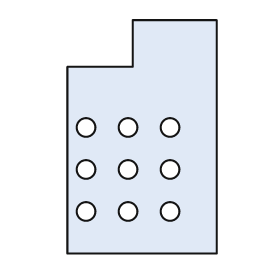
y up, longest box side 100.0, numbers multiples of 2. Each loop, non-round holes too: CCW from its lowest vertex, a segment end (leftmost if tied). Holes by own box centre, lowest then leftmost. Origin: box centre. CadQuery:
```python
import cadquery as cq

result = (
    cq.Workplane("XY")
    .moveTo(-32.0, -50.0)
    .lineTo(32.0, -50.0)
    .lineTo(32.0, 50.0)
    .lineTo(-4.0, 50.0)
    .lineTo(-4.0, 30.0)
    .lineTo(-32.0, 30.0)
    .close()
    .moveTo(-24.0, -32.0)
    .circle(4.0)
    .moveTo(-6.0, -32.0)
    .circle(4.0)
    .moveTo(12.0, -32.0)
    .circle(4.0)
    .moveTo(-24.0, -14.0)
    .circle(4.0)
    .moveTo(-6.0, -14.0)
    .circle(4.0)
    .moveTo(12.0, -14.0)
    .circle(4.0)
    .moveTo(-24.0, 4.0)
    .circle(4.0)
    .moveTo(-6.0, 4.0)
    .circle(4.0)
    .moveTo(12.0, 4.0)
    .circle(4.0)
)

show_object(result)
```